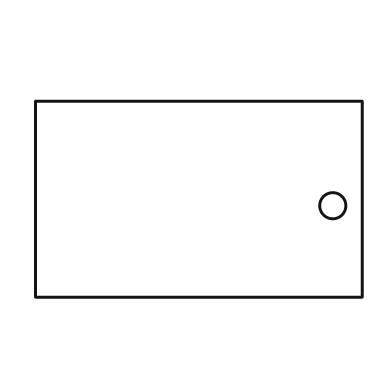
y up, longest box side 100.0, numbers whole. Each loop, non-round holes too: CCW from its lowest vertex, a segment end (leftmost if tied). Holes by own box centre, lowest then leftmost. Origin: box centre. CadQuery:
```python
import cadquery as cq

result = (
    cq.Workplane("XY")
    .moveTo(-50.0, -30.0)
    .lineTo(50.0, -30.0)
    .lineTo(50.0, 30.0)
    .lineTo(-50.0, 30.0)
    .close()
    .moveTo(41.0, -2.0)
    .circle(4.0)
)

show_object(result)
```